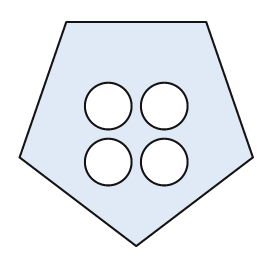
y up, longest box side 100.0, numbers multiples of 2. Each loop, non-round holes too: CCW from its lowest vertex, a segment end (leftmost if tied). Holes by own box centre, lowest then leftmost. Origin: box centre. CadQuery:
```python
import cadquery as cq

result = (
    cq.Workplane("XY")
    .moveTo(0.0, -48.0)
    .lineTo(50.0, -10.0)
    .lineTo(30.0, 48.0)
    .lineTo(-30.0, 48.0)
    .lineTo(-50.0, -10.0)
    .close()
    .moveTo(-12.0, -12.0)
    .circle(10.0)
    .moveTo(12.0, -12.0)
    .circle(10.0)
    .moveTo(-12.0, 12.0)
    .circle(10.0)
    .moveTo(12.0, 12.0)
    .circle(10.0)
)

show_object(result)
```